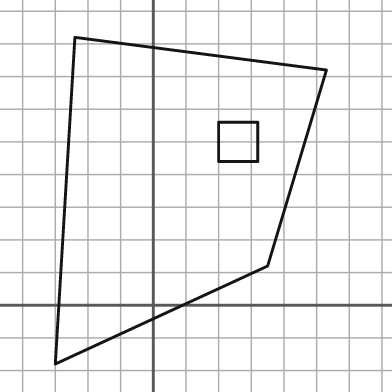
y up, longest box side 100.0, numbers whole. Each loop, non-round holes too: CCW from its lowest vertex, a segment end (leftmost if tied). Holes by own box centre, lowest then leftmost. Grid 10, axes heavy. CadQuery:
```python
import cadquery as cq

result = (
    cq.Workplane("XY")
    .moveTo(-30.0, -18.0)
    .lineTo(35.0, 12.0)
    .lineTo(53.0, 72.0)
    .lineTo(-24.0, 82.0)
    .close()
    .moveTo(20.0, 44.0)
    .lineTo(32.0, 44.0)
    .lineTo(32.0, 56.0)
    .lineTo(20.0, 56.0)
    .close()
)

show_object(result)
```